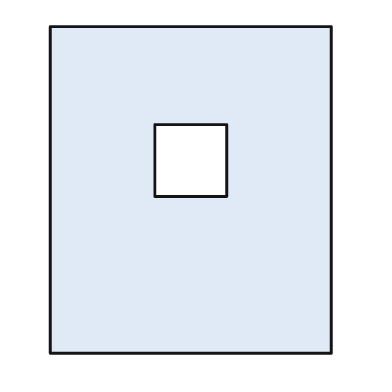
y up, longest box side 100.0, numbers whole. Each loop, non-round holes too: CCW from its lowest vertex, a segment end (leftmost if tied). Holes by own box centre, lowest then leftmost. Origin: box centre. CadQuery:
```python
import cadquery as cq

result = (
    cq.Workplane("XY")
    .moveTo(-43.0, -50.0)
    .lineTo(43.0, -50.0)
    .lineTo(43.0, 50.0)
    .lineTo(-43.0, 50.0)
    .close()
    .moveTo(-11.0, -2.0)
    .lineTo(11.0, -2.0)
    .lineTo(11.0, 20.0)
    .lineTo(-11.0, 20.0)
    .close()
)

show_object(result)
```